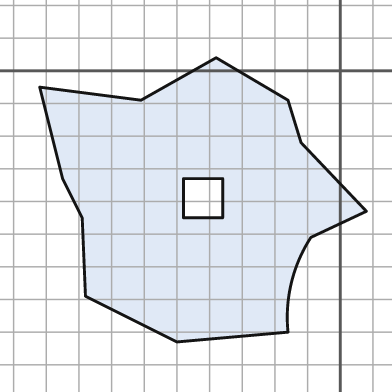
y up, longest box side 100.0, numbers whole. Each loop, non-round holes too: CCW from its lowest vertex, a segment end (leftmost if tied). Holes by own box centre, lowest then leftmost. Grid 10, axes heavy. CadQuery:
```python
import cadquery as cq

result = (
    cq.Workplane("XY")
    .moveTo(-50.0, -83.0)
    .lineTo(-16.0, -80.0)
    .threePointArc((-15.0, -65.0), (-9.0, -51.0))
    .lineTo(8.0, -43.0)
    .lineTo(-12.0, -22.0)
    .lineTo(-16.0, -9.0)
    .lineTo(-38.0, 4.0)
    .lineTo(-61.0, -9.0)
    .lineTo(-92.0, -5.0)
    .lineTo(-85.0, -33.0)
    .lineTo(-79.0, -45.0)
    .lineTo(-78.0, -69.0)
    .close()
    .moveTo(-48.0, -45.0)
    .lineTo(-36.0, -45.0)
    .lineTo(-36.0, -33.0)
    .lineTo(-48.0, -33.0)
    .close()
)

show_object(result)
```